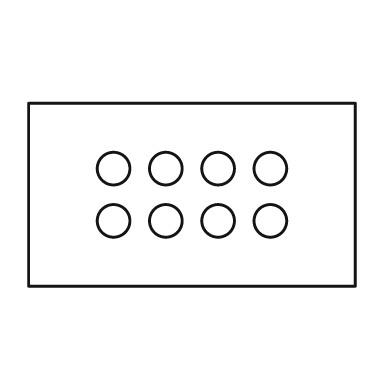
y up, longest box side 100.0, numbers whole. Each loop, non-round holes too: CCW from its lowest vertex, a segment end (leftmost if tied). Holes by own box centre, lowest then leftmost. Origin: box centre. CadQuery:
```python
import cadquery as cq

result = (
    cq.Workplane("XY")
    .moveTo(-50.0, -28.0)
    .lineTo(50.0, -28.0)
    .lineTo(50.0, 28.0)
    .lineTo(-50.0, 28.0)
    .close()
    .moveTo(-24.0, -8.0)
    .circle(5.0)
    .moveTo(-8.0, -8.0)
    .circle(5.0)
    .moveTo(8.0, -8.0)
    .circle(5.0)
    .moveTo(24.0, -8.0)
    .circle(5.0)
    .moveTo(-24.0, 8.0)
    .circle(5.0)
    .moveTo(-8.0, 8.0)
    .circle(5.0)
    .moveTo(8.0, 8.0)
    .circle(5.0)
    .moveTo(24.0, 8.0)
    .circle(5.0)
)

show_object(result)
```